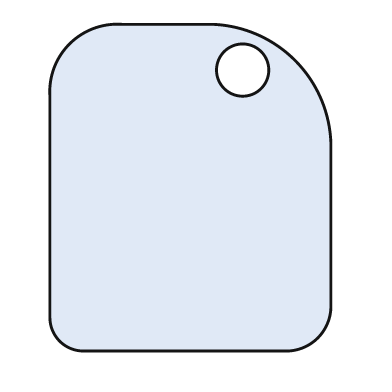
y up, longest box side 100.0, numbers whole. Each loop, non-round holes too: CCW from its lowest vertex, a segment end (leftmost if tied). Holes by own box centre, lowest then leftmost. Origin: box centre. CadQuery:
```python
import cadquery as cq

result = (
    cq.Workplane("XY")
    .moveTo(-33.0, -50.0)
    .lineTo(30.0, -50.0)
    .threePointArc((39.0, -46.0), (43.0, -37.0))
    .lineTo(43.0, 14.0)
    .threePointArc((32.0, 39.0), (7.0, 50.0))
    .lineTo(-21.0, 50.0)
    .threePointArc((-37.0, 44.0), (-43.0, 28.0))
    .lineTo(-43.0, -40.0)
    .threePointArc((-40.0, -47.0), (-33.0, -50.0))
    .close()
    .moveTo(16.0, 36.0)
    .circle(8.0)
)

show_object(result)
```